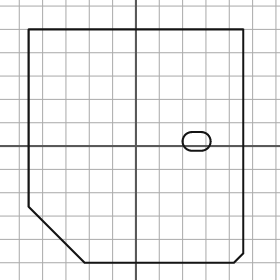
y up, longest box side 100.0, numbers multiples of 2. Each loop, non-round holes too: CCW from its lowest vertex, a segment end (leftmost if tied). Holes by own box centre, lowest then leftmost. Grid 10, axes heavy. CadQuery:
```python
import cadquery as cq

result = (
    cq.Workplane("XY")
    .moveTo(-22.0, -50.0)
    .lineTo(42.0, -50.0)
    .lineTo(46.0, -46.0)
    .lineTo(46.0, 50.0)
    .lineTo(-46.0, 50.0)
    .lineTo(-46.0, -26.0)
    .close()
    .moveTo(24.0, -2.0)
    .lineTo(28.0, -2.0)
    .threePointArc((32.0, 2.0), (28.0, 6.0))
    .lineTo(24.0, 6.0)
    .threePointArc((20.0, 2.0), (24.0, -2.0))
    .close()
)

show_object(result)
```